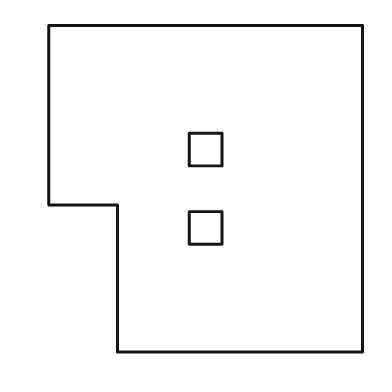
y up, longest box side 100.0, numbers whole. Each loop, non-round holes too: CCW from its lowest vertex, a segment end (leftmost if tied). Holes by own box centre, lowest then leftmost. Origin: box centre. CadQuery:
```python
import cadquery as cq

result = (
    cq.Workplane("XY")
    .moveTo(-27.0, -50.0)
    .lineTo(48.0, -50.0)
    .lineTo(48.0, 50.0)
    .lineTo(-48.0, 50.0)
    .lineTo(-48.0, -5.0)
    .lineTo(-27.0, -5.0)
    .close()
    .moveTo(-5.0, -17.0)
    .lineTo(5.0, -17.0)
    .lineTo(5.0, -7.0)
    .lineTo(-5.0, -7.0)
    .close()
    .moveTo(-5.0, 7.0)
    .lineTo(5.0, 7.0)
    .lineTo(5.0, 17.0)
    .lineTo(-5.0, 17.0)
    .close()
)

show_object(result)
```